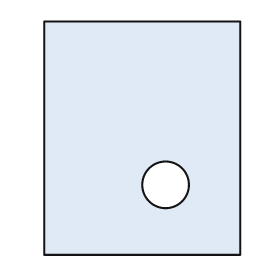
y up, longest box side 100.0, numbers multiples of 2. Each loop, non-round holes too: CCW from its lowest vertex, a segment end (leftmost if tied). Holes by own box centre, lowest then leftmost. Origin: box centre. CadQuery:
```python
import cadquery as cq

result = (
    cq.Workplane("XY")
    .moveTo(-42.0, -50.0)
    .lineTo(42.0, -50.0)
    .lineTo(42.0, 50.0)
    .lineTo(-42.0, 50.0)
    .close()
    .moveTo(10.0, -20.0)
    .circle(10.0)
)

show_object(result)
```